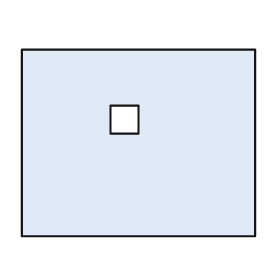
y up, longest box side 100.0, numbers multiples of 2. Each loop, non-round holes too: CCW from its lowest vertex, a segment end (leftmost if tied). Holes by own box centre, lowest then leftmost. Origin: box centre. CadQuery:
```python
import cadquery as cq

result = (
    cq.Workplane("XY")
    .moveTo(-50.0, -40.0)
    .lineTo(50.0, -40.0)
    .lineTo(50.0, 40.0)
    .lineTo(-50.0, 40.0)
    .close()
    .moveTo(-12.0, 4.0)
    .lineTo(0.0, 4.0)
    .lineTo(0.0, 16.0)
    .lineTo(-12.0, 16.0)
    .close()
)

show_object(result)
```